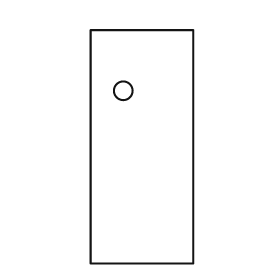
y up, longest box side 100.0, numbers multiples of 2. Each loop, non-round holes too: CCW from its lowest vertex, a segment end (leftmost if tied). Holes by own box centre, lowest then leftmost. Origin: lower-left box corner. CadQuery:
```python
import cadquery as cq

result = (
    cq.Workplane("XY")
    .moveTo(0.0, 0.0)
    .lineTo(44.0, 0.0)
    .lineTo(44.0, 100.0)
    .lineTo(0.0, 100.0)
    .close()
    .moveTo(14.0, 74.0)
    .circle(4.0)
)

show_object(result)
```